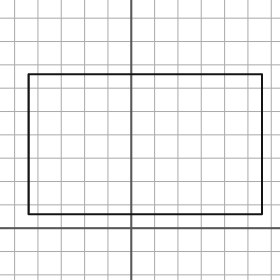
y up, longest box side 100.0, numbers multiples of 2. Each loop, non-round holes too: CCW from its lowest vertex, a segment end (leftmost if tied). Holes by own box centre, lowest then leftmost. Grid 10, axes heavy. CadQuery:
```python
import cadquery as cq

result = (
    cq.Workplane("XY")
    .moveTo(-44.0, 6.0)
    .lineTo(56.0, 6.0)
    .lineTo(56.0, 66.0)
    .lineTo(-44.0, 66.0)
    .close()
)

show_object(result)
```